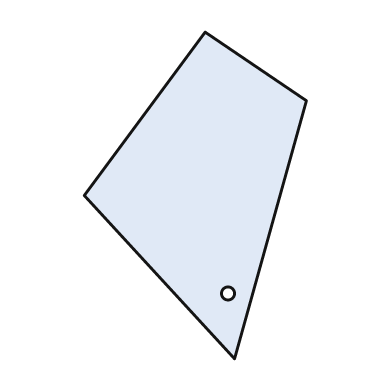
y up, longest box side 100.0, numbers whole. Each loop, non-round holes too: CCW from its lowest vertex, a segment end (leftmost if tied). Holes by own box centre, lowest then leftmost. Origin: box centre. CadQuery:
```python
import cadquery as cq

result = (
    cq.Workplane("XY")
    .moveTo(12.0, -50.0)
    .lineTo(34.0, 29.0)
    .lineTo(3.0, 50.0)
    .lineTo(-34.0, 0.0)
    .close()
    .moveTo(10.0, -30.0)
    .circle(2.0)
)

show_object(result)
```